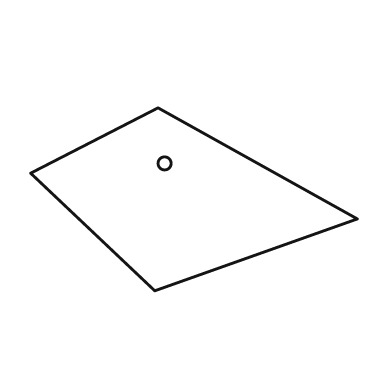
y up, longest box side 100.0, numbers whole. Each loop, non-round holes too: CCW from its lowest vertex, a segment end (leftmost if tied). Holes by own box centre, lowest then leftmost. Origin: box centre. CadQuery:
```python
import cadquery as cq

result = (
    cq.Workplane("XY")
    .moveTo(-12.0, -28.0)
    .lineTo(50.0, -6.0)
    .lineTo(-11.0, 28.0)
    .lineTo(-50.0, 8.0)
    .close()
    .moveTo(-9.0, 11.0)
    .circle(2.0)
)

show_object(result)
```